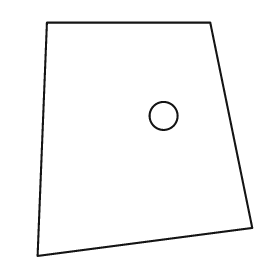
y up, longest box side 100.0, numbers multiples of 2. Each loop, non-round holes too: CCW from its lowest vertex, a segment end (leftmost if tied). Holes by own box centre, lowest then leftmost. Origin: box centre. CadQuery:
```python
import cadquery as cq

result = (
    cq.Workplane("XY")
    .moveTo(-46.0, -50.0)
    .lineTo(46.0, -38.0)
    .lineTo(28.0, 50.0)
    .lineTo(-42.0, 50.0)
    .close()
    .moveTo(8.0, 10.0)
    .circle(6.0)
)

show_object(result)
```